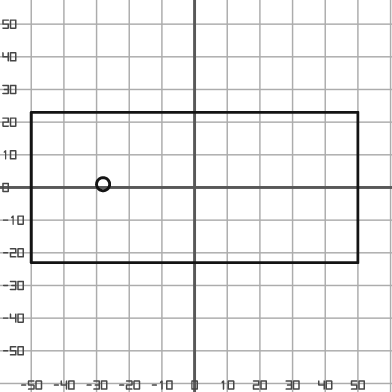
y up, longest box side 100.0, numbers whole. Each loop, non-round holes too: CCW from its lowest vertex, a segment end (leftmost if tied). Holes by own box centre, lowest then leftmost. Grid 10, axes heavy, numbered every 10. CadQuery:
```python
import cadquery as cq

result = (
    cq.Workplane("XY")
    .moveTo(-50.0, -23.0)
    .lineTo(50.0, -23.0)
    .lineTo(50.0, 23.0)
    .lineTo(-50.0, 23.0)
    .close()
    .moveTo(-28.0, 1.0)
    .circle(2.0)
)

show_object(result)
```